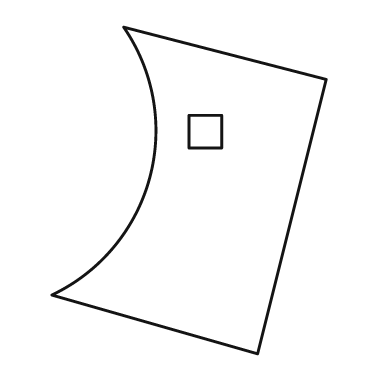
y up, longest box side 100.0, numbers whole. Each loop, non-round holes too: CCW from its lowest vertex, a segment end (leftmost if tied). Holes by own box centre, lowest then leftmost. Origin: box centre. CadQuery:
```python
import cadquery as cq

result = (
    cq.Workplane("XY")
    .moveTo(21.0, -50.0)
    .lineTo(42.0, 34.0)
    .lineTo(-20.0, 50.0)
    .threePointArc((-12.0, 4.0), (-42.0, -32.0))
    .close()
    .moveTo(0.0, 13.0)
    .lineTo(10.0, 13.0)
    .lineTo(10.0, 23.0)
    .lineTo(0.0, 23.0)
    .close()
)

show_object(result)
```